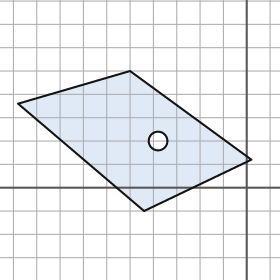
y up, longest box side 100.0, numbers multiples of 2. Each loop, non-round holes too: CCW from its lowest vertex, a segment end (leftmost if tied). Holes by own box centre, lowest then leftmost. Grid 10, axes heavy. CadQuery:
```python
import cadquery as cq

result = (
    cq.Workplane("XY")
    .moveTo(-44.0, -10.0)
    .lineTo(2.0, 12.0)
    .lineTo(-50.0, 50.0)
    .lineTo(-98.0, 36.0)
    .close()
    .moveTo(-38.0, 20.0)
    .circle(4.0)
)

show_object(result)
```